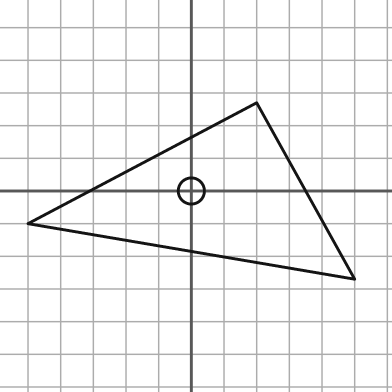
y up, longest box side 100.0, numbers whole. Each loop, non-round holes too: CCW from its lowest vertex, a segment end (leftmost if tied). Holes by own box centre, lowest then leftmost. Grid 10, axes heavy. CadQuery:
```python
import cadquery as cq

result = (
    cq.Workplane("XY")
    .moveTo(50.0, -27.0)
    .lineTo(20.0, 27.0)
    .lineTo(-50.0, -10.0)
    .close()
    .moveTo(0.0, 0.0)
    .circle(4.0)
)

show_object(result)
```